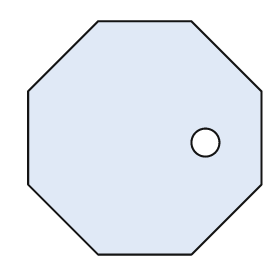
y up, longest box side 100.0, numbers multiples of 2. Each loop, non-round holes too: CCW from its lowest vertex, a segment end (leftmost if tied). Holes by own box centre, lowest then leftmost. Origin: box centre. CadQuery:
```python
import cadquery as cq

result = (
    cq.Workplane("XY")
    .moveTo(-20.0, -50.0)
    .lineTo(20.0, -50.0)
    .lineTo(50.0, -20.0)
    .lineTo(50.0, 20.0)
    .lineTo(20.0, 50.0)
    .lineTo(-20.0, 50.0)
    .lineTo(-50.0, 20.0)
    .lineTo(-50.0, -20.0)
    .close()
    .moveTo(26.0, -2.0)
    .circle(6.0)
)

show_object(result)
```